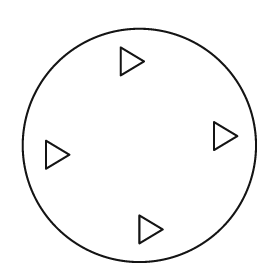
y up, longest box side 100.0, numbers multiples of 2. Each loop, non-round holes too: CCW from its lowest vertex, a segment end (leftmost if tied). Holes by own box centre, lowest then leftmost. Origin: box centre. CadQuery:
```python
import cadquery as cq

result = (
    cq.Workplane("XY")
    .moveTo(0.0, 0.0)
    .circle(50.0)
    .moveTo(0.0, -42.0)
    .lineTo(10.0, -36.0)
    .lineTo(0.0, -30.0)
    .close()
    .moveTo(-40.0, -10.0)
    .lineTo(-30.0, -4.0)
    .lineTo(-40.0, 2.0)
    .close()
    .moveTo(32.0, -2.0)
    .lineTo(42.0, 4.0)
    .lineTo(32.0, 10.0)
    .close()
    .moveTo(-8.0, 30.0)
    .lineTo(2.0, 36.0)
    .lineTo(-8.0, 42.0)
    .close()
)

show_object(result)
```